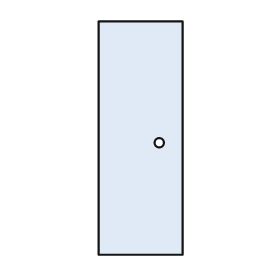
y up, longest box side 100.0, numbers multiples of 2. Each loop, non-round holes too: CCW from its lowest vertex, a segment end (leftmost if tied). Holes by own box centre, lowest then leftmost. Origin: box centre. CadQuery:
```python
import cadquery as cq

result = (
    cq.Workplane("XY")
    .moveTo(-18.0, -50.0)
    .lineTo(18.0, -50.0)
    .lineTo(18.0, 50.0)
    .lineTo(-18.0, 50.0)
    .close()
    .moveTo(8.0, -2.0)
    .circle(2.0)
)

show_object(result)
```